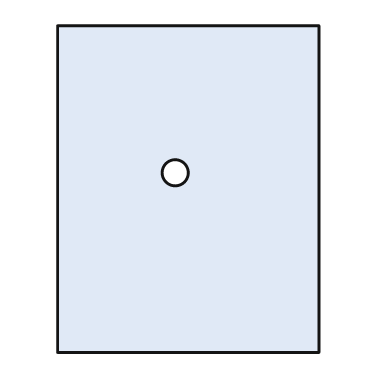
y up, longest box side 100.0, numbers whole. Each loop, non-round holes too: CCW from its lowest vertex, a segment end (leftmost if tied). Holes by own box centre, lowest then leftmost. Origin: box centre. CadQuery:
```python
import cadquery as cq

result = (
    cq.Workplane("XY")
    .moveTo(-40.0, -50.0)
    .lineTo(40.0, -50.0)
    .lineTo(40.0, 50.0)
    .lineTo(-40.0, 50.0)
    .close()
    .moveTo(-4.0, 5.0)
    .circle(4.0)
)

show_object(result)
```